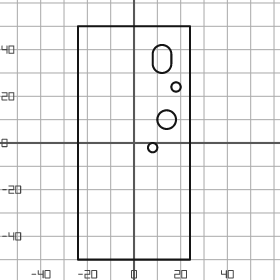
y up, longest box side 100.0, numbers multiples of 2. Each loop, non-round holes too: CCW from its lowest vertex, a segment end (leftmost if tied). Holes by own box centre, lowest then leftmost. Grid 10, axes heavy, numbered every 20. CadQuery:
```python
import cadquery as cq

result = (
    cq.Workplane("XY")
    .moveTo(-24.0, -50.0)
    .lineTo(24.0, -50.0)
    .lineTo(24.0, 50.0)
    .lineTo(-24.0, 50.0)
    .close()
    .moveTo(8.0, -2.0)
    .circle(2.0)
    .moveTo(14.0, 10.0)
    .circle(4.0)
    .moveTo(18.0, 24.0)
    .circle(2.0)
    .moveTo(8.0, 34.0)
    .threePointArc((12.0, 30.0), (16.0, 34.0))
    .lineTo(16.0, 38.0)
    .threePointArc((12.0, 42.0), (8.0, 38.0))
    .close()
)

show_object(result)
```